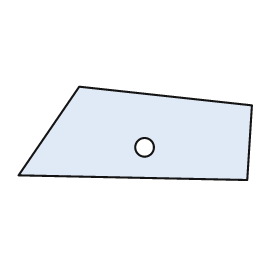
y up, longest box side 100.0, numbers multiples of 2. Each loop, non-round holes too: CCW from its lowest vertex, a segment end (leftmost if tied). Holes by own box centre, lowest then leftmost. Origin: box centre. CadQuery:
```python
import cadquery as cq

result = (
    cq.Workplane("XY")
    .moveTo(48.0, -20.0)
    .lineTo(50.0, 12.0)
    .lineTo(-24.0, 20.0)
    .lineTo(-50.0, -18.0)
    .close()
    .moveTo(4.0, -6.0)
    .circle(4.0)
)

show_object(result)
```